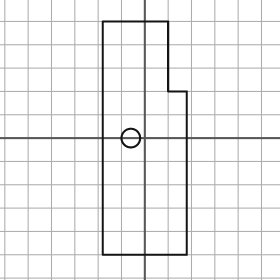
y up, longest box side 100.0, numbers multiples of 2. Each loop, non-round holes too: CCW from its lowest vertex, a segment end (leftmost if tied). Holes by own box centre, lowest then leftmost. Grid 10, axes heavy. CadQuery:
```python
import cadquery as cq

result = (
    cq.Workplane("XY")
    .moveTo(-18.0, -50.0)
    .lineTo(18.0, -50.0)
    .lineTo(18.0, 20.0)
    .lineTo(10.0, 20.0)
    .lineTo(10.0, 50.0)
    .lineTo(-18.0, 50.0)
    .close()
    .moveTo(-6.0, 0.0)
    .circle(4.0)
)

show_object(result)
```